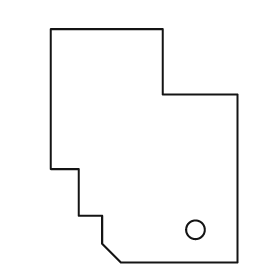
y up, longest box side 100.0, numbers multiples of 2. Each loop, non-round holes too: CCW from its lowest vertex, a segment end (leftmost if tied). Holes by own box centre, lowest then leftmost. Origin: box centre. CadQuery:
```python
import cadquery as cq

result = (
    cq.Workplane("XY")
    .moveTo(-10.0, -50.0)
    .lineTo(40.0, -50.0)
    .lineTo(40.0, 22.0)
    .lineTo(8.0, 22.0)
    .lineTo(8.0, 50.0)
    .lineTo(-40.0, 50.0)
    .lineTo(-40.0, -10.0)
    .lineTo(-28.0, -10.0)
    .lineTo(-28.0, -30.0)
    .lineTo(-18.0, -30.0)
    .lineTo(-18.0, -42.0)
    .close()
    .moveTo(22.0, -36.0)
    .circle(4.0)
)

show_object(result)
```